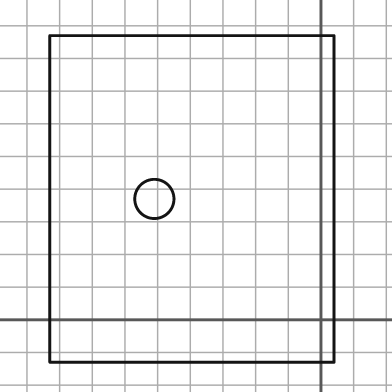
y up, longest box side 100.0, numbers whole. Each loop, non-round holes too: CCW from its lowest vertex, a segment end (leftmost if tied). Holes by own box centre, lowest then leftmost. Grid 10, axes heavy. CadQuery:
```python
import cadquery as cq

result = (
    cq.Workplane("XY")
    .moveTo(-83.0, -13.0)
    .lineTo(4.0, -13.0)
    .lineTo(4.0, 87.0)
    .lineTo(-83.0, 87.0)
    .close()
    .moveTo(-51.0, 37.0)
    .circle(6.0)
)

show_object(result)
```